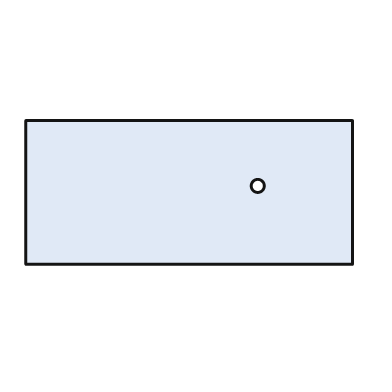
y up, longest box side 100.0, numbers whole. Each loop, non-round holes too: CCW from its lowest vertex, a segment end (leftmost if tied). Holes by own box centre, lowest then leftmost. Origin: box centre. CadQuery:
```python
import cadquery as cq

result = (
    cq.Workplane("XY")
    .moveTo(-50.0, -22.0)
    .lineTo(50.0, -22.0)
    .lineTo(50.0, 22.0)
    .lineTo(-50.0, 22.0)
    .close()
    .moveTo(21.0, 2.0)
    .circle(2.0)
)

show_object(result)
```